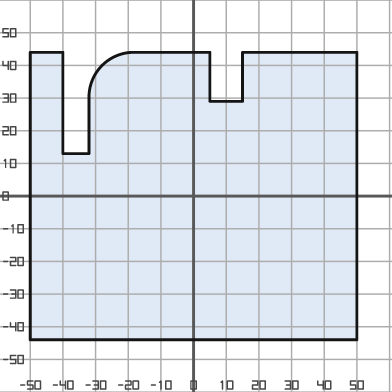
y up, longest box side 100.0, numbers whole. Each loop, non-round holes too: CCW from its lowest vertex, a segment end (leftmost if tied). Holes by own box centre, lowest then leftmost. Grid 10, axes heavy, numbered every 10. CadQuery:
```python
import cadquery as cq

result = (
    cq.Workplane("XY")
    .moveTo(-50.0, -44.0)
    .lineTo(50.0, -44.0)
    .lineTo(50.0, 44.0)
    .lineTo(15.0, 44.0)
    .lineTo(15.0, 29.0)
    .lineTo(5.0, 29.0)
    .lineTo(5.0, 44.0)
    .lineTo(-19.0, 44.0)
    .threePointArc((-28.0, 40.0), (-32.0, 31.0))
    .lineTo(-32.0, 13.0)
    .lineTo(-40.0, 13.0)
    .lineTo(-40.0, 44.0)
    .lineTo(-50.0, 44.0)
    .close()
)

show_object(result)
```